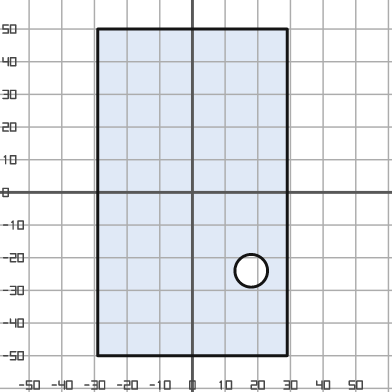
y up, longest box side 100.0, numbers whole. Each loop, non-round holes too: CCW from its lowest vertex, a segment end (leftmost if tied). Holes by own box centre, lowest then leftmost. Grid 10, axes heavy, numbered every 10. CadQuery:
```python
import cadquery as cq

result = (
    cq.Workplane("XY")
    .moveTo(-29.0, -50.0)
    .lineTo(29.0, -50.0)
    .lineTo(29.0, 50.0)
    .lineTo(-29.0, 50.0)
    .close()
    .moveTo(18.0, -24.0)
    .circle(5.0)
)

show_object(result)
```